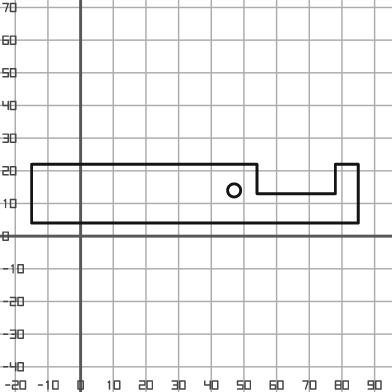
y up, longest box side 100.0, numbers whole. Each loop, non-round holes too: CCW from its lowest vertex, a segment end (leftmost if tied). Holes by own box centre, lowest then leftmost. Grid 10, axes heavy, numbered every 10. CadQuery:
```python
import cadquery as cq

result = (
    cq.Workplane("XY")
    .moveTo(-15.0, 4.0)
    .lineTo(85.0, 4.0)
    .lineTo(85.0, 22.0)
    .lineTo(78.0, 22.0)
    .lineTo(78.0, 13.0)
    .lineTo(54.0, 13.0)
    .lineTo(54.0, 22.0)
    .lineTo(-15.0, 22.0)
    .close()
    .moveTo(47.0, 14.0)
    .circle(2.0)
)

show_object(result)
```